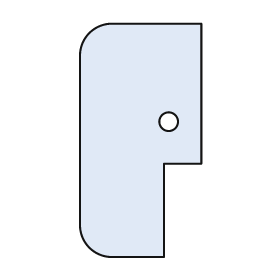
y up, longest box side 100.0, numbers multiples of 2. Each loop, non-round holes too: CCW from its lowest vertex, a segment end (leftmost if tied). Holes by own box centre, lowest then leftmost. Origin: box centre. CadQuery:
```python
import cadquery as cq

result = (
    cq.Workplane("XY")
    .moveTo(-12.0, -50.0)
    .lineTo(10.0, -50.0)
    .lineTo(10.0, -10.0)
    .lineTo(26.0, -10.0)
    .lineTo(26.0, 50.0)
    .lineTo(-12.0, 50.0)
    .threePointArc((-22.0, 46.0), (-26.0, 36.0))
    .lineTo(-26.0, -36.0)
    .threePointArc((-22.0, -46.0), (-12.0, -50.0))
    .close()
    .moveTo(12.0, 8.0)
    .circle(4.0)
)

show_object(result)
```